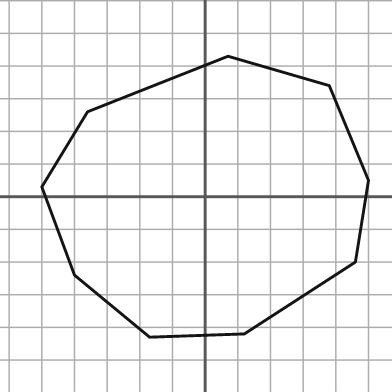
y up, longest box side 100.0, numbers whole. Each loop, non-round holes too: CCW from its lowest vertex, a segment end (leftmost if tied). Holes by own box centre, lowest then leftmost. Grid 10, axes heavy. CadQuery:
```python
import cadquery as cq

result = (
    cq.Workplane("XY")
    .moveTo(-17.0, -43.0)
    .lineTo(12.0, -42.0)
    .lineTo(46.0, -20.0)
    .lineTo(50.0, 5.0)
    .lineTo(38.0, 34.0)
    .lineTo(7.0, 43.0)
    .lineTo(-36.0, 26.0)
    .lineTo(-50.0, 3.0)
    .lineTo(-40.0, -24.0)
    .close()
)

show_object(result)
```